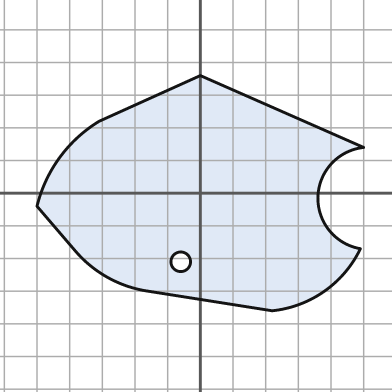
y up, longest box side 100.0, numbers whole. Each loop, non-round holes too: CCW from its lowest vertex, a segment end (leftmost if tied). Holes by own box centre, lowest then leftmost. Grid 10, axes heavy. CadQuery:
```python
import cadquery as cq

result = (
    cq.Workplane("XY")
    .moveTo(22.0, -36.0)
    .threePointArc((38.0, -30.0), (49.0, -17.0))
    .threePointArc((36.0, -1.0), (50.0, 14.0))
    .lineTo(0.0, 36.0)
    .lineTo(-31.0, 22.0)
    .threePointArc((-43.0, 11.0), (-50.0, -4.0))
    .lineTo(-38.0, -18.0)
    .threePointArc((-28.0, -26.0), (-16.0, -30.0))
    .close()
    .moveTo(-6.0, -21.0)
    .circle(3.0)
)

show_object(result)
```